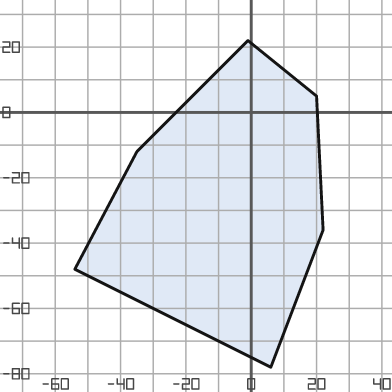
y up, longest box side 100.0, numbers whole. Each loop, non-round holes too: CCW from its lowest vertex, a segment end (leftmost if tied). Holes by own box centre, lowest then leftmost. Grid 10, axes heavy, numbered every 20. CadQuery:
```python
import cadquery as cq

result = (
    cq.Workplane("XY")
    .moveTo(6.0, -78.0)
    .lineTo(22.0, -36.0)
    .lineTo(20.0, 5.0)
    .lineTo(-1.0, 22.0)
    .lineTo(-35.0, -12.0)
    .lineTo(-54.0, -48.0)
    .close()
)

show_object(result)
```